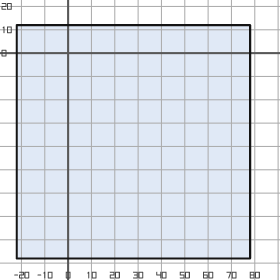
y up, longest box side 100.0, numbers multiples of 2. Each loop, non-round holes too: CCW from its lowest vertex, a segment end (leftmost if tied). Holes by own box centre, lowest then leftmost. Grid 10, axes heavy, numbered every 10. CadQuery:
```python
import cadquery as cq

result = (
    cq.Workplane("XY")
    .moveTo(-22.0, -88.0)
    .lineTo(78.0, -88.0)
    .lineTo(78.0, 12.0)
    .lineTo(-22.0, 12.0)
    .close()
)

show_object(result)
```